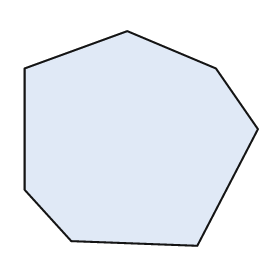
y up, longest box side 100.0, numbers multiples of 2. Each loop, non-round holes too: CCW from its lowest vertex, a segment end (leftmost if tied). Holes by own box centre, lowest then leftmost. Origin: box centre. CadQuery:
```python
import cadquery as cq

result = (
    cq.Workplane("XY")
    .moveTo(24.0, -46.0)
    .lineTo(50.0, 4.0)
    .lineTo(32.0, 30.0)
    .lineTo(-6.0, 46.0)
    .lineTo(-50.0, 30.0)
    .lineTo(-50.0, -22.0)
    .lineTo(-30.0, -44.0)
    .close()
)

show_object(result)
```